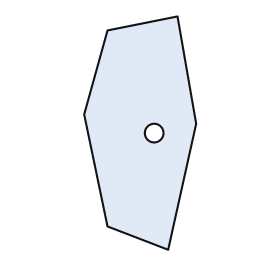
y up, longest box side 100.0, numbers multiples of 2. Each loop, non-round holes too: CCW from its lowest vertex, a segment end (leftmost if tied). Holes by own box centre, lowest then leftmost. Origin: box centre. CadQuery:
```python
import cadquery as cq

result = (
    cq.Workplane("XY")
    .moveTo(12.0, -50.0)
    .lineTo(24.0, 4.0)
    .lineTo(16.0, 50.0)
    .lineTo(-14.0, 44.0)
    .lineTo(-24.0, 8.0)
    .lineTo(-14.0, -40.0)
    .close()
    .moveTo(6.0, 0.0)
    .circle(4.0)
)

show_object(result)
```